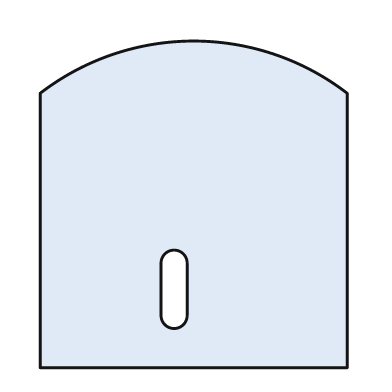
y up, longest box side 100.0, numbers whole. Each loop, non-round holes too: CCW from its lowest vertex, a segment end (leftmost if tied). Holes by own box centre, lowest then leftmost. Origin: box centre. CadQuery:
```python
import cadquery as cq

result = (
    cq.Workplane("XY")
    .moveTo(-47.0, -50.0)
    .lineTo(47.0, -50.0)
    .lineTo(47.0, 34.0)
    .threePointArc((0.0, 50.0), (-47.0, 34.0))
    .close()
    .moveTo(-10.0, -34.0)
    .threePointArc((-6.0, -38.0), (-2.0, -34.0))
    .lineTo(-2.0, -18.0)
    .threePointArc((-6.0, -14.0), (-10.0, -18.0))
    .close()
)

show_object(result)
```